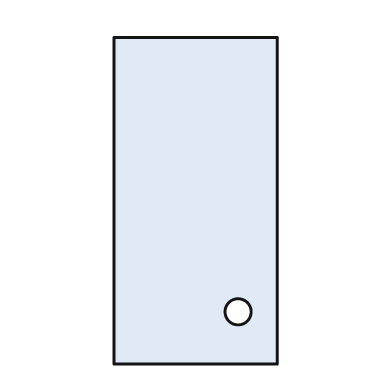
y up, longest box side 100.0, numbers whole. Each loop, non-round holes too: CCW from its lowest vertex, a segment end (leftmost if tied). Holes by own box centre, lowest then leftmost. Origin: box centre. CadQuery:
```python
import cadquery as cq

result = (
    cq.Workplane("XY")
    .moveTo(-25.0, -50.0)
    .lineTo(25.0, -50.0)
    .lineTo(25.0, 50.0)
    .lineTo(-25.0, 50.0)
    .close()
    .moveTo(13.0, -34.0)
    .circle(4.0)
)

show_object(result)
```